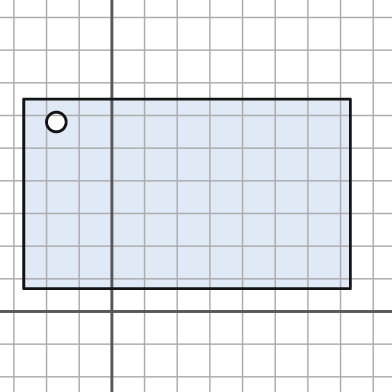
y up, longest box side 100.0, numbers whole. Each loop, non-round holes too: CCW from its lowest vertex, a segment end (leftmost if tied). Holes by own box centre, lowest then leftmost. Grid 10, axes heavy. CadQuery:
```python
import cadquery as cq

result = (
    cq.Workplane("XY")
    .moveTo(-27.0, 7.0)
    .lineTo(73.0, 7.0)
    .lineTo(73.0, 65.0)
    .lineTo(-27.0, 65.0)
    .close()
    .moveTo(-17.0, 58.0)
    .circle(3.0)
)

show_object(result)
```